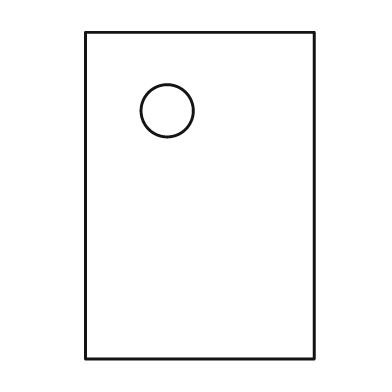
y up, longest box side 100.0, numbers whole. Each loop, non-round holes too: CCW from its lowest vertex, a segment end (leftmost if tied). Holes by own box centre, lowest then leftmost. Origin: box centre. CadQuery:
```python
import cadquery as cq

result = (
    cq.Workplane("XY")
    .moveTo(-35.0, -50.0)
    .lineTo(35.0, -50.0)
    .lineTo(35.0, 50.0)
    .lineTo(-35.0, 50.0)
    .close()
    .moveTo(-10.0, 26.0)
    .circle(8.0)
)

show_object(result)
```